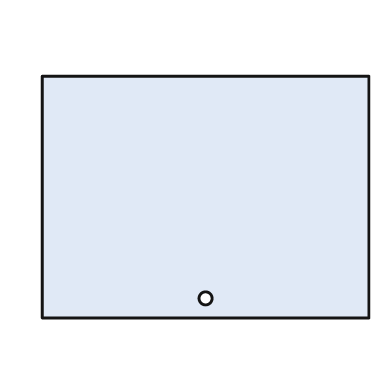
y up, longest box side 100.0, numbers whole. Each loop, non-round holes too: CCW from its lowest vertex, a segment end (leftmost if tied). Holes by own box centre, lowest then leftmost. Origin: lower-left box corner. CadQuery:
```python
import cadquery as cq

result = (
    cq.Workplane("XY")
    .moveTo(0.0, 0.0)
    .lineTo(100.0, 0.0)
    .lineTo(100.0, 74.0)
    .lineTo(0.0, 74.0)
    .close()
    .moveTo(50.0, 6.0)
    .circle(2.0)
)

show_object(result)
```